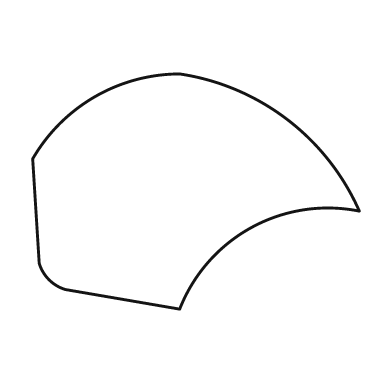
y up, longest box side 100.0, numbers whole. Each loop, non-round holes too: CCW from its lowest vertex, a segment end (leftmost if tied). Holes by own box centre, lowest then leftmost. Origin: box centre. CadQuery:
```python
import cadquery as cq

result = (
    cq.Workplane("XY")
    .moveTo(-5.0, -36.0)
    .threePointArc((17.0, -11.0), (50.0, -6.0))
    .threePointArc((28.0, 22.0), (-5.0, 36.0))
    .threePointArc((-31.0, 29.0), (-50.0, 10.0))
    .lineTo(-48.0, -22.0)
    .threePointArc((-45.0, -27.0), (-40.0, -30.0))
    .close()
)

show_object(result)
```